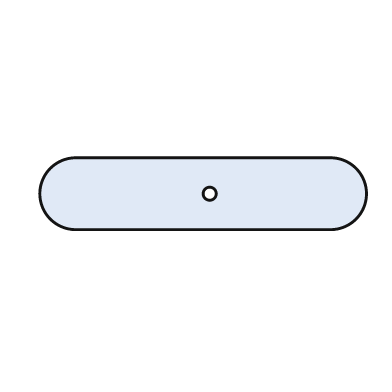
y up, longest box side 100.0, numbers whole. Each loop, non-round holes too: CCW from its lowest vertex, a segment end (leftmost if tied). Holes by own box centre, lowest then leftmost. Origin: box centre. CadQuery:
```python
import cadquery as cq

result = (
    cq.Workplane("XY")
    .moveTo(-39.0, -11.0)
    .lineTo(39.0, -11.0)
    .threePointArc((50.0, 0.0), (39.0, 11.0))
    .lineTo(-39.0, 11.0)
    .threePointArc((-50.0, 0.0), (-39.0, -11.0))
    .close()
    .moveTo(2.0, 0.0)
    .circle(2.0)
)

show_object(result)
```